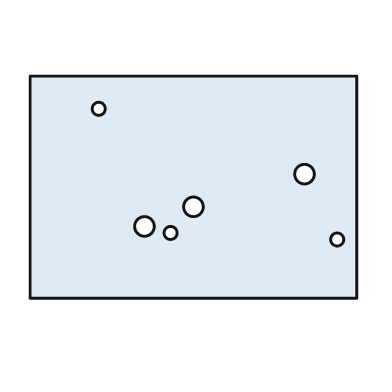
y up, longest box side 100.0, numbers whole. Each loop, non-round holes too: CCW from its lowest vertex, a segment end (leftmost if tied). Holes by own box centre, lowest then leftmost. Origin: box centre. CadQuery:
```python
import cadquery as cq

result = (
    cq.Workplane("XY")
    .moveTo(-50.0, -34.0)
    .lineTo(50.0, -34.0)
    .lineTo(50.0, 34.0)
    .lineTo(-50.0, 34.0)
    .close()
    .moveTo(44.0, -16.0)
    .circle(2.0)
    .moveTo(-7.0, -14.0)
    .circle(2.0)
    .moveTo(-15.0, -12.0)
    .circle(3.0)
    .moveTo(0.0, -6.0)
    .circle(3.0)
    .moveTo(34.0, 4.0)
    .circle(3.0)
    .moveTo(-29.0, 24.0)
    .circle(2.0)
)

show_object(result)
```